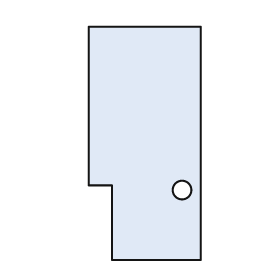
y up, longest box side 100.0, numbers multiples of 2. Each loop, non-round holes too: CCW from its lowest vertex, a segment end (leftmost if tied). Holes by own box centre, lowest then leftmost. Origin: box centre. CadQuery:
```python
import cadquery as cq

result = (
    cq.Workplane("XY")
    .moveTo(-14.0, -50.0)
    .lineTo(24.0, -50.0)
    .lineTo(24.0, 50.0)
    .lineTo(-24.0, 50.0)
    .lineTo(-24.0, -18.0)
    .lineTo(-14.0, -18.0)
    .close()
    .moveTo(16.0, -20.0)
    .circle(4.0)
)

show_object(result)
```